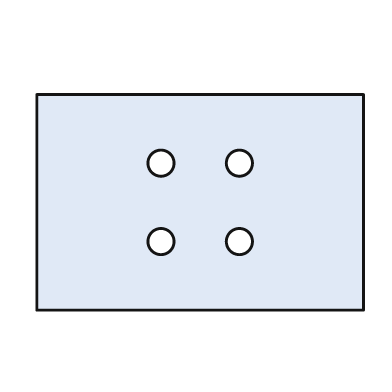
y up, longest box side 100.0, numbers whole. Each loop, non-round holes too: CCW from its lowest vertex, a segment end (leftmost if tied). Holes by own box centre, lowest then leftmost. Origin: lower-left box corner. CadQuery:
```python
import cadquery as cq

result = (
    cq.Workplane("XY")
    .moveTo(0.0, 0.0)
    .lineTo(100.0, 0.0)
    .lineTo(100.0, 66.0)
    .lineTo(0.0, 66.0)
    .close()
    .moveTo(38.0, 21.0)
    .circle(4.0)
    .moveTo(62.0, 21.0)
    .circle(4.0)
    .moveTo(38.0, 45.0)
    .circle(4.0)
    .moveTo(62.0, 45.0)
    .circle(4.0)
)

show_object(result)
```